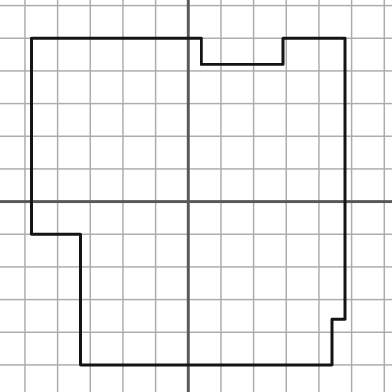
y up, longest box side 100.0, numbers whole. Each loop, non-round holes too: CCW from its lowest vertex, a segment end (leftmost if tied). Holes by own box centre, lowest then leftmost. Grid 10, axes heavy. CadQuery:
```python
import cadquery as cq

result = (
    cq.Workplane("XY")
    .moveTo(-33.0, -50.0)
    .lineTo(44.0, -50.0)
    .lineTo(44.0, -36.0)
    .lineTo(48.0, -36.0)
    .lineTo(48.0, 50.0)
    .lineTo(29.0, 50.0)
    .lineTo(29.0, 42.0)
    .lineTo(4.0, 42.0)
    .lineTo(4.0, 50.0)
    .lineTo(-48.0, 50.0)
    .lineTo(-48.0, -10.0)
    .lineTo(-33.0, -10.0)
    .close()
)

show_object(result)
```